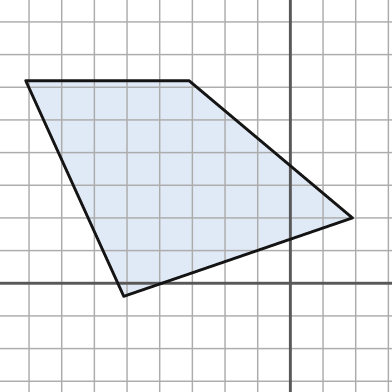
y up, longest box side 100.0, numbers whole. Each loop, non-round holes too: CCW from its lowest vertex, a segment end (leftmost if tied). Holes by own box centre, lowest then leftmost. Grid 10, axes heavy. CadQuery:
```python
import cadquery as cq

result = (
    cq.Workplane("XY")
    .moveTo(-51.0, -4.0)
    .lineTo(19.0, 20.0)
    .lineTo(-31.0, 62.0)
    .lineTo(-81.0, 62.0)
    .close()
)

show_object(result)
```